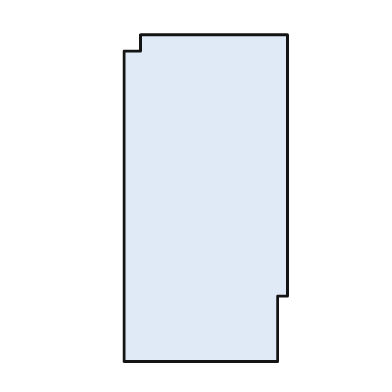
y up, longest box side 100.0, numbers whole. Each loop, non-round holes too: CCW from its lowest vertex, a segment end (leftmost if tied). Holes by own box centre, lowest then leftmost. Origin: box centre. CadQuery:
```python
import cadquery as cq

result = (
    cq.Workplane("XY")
    .moveTo(-25.0, -50.0)
    .lineTo(22.0, -50.0)
    .lineTo(22.0, -30.0)
    .lineTo(25.0, -30.0)
    .lineTo(25.0, 50.0)
    .lineTo(-20.0, 50.0)
    .lineTo(-20.0, 45.0)
    .lineTo(-25.0, 45.0)
    .close()
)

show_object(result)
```